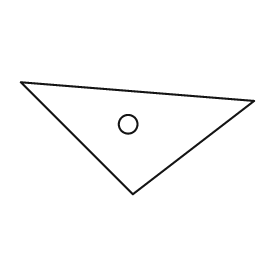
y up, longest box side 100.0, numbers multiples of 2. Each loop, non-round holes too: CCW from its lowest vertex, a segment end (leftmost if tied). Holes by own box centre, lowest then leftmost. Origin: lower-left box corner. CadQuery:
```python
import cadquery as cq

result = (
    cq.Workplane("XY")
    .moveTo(48.0, 0.0)
    .lineTo(100.0, 40.0)
    .lineTo(0.0, 48.0)
    .close()
    .moveTo(46.0, 30.0)
    .circle(4.0)
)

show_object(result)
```